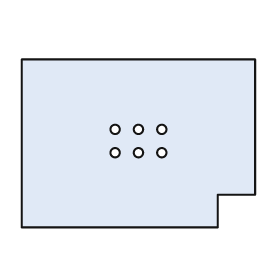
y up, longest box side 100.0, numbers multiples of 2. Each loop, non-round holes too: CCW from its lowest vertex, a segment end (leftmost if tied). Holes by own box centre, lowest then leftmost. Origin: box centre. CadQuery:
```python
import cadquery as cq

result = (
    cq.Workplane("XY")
    .moveTo(-50.0, -36.0)
    .lineTo(34.0, -36.0)
    .lineTo(34.0, -22.0)
    .lineTo(50.0, -22.0)
    .lineTo(50.0, 36.0)
    .lineTo(-50.0, 36.0)
    .close()
    .moveTo(-10.0, -4.0)
    .circle(2.0)
    .moveTo(0.0, -4.0)
    .circle(2.0)
    .moveTo(10.0, -4.0)
    .circle(2.0)
    .moveTo(-10.0, 6.0)
    .circle(2.0)
    .moveTo(0.0, 6.0)
    .circle(2.0)
    .moveTo(10.0, 6.0)
    .circle(2.0)
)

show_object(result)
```